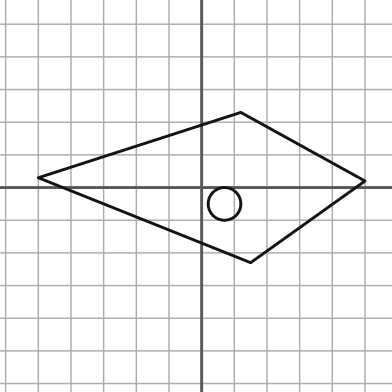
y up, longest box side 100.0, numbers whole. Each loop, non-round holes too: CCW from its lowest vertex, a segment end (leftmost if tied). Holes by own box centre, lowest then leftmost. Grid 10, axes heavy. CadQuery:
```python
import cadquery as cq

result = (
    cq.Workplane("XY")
    .moveTo(15.0, -23.0)
    .lineTo(50.0, 2.0)
    .lineTo(12.0, 23.0)
    .lineTo(-50.0, 3.0)
    .close()
    .moveTo(7.0, -5.0)
    .circle(5.0)
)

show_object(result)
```